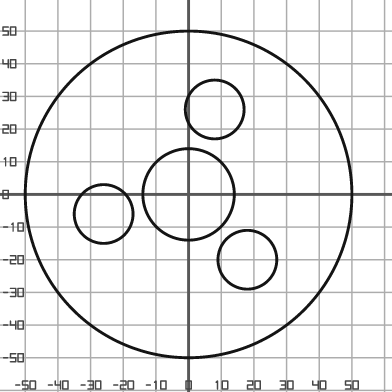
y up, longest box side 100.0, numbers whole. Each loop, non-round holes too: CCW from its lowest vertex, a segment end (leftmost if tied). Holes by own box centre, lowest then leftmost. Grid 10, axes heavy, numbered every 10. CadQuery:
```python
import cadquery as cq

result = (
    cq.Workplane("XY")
    .moveTo(0.0, 0.0)
    .circle(50.0)
    .moveTo(18.0, -20.0)
    .circle(9.0)
    .moveTo(-26.0, -6.0)
    .circle(9.0)
    .moveTo(0.0, 0.0)
    .circle(14.0)
    .moveTo(8.0, 26.0)
    .circle(9.0)
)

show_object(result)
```